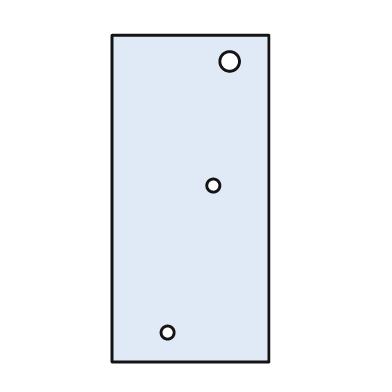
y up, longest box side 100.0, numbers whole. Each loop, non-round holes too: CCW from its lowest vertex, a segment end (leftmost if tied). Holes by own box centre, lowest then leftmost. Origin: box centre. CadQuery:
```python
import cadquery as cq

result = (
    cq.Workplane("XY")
    .moveTo(-24.0, -50.0)
    .lineTo(24.0, -50.0)
    .lineTo(24.0, 50.0)
    .lineTo(-24.0, 50.0)
    .close()
    .moveTo(-7.0, -41.0)
    .circle(2.0)
    .moveTo(7.0, 4.0)
    .circle(2.0)
    .moveTo(12.0, 42.0)
    .circle(3.0)
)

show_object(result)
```